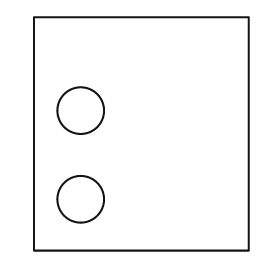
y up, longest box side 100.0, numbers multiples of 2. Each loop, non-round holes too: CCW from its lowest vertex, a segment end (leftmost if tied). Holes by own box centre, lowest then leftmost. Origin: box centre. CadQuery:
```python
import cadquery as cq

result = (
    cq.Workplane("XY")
    .moveTo(-46.0, -50.0)
    .lineTo(46.0, -50.0)
    .lineTo(46.0, 50.0)
    .lineTo(-46.0, 50.0)
    .close()
    .moveTo(-26.0, -28.0)
    .circle(10.0)
    .moveTo(-26.0, 10.0)
    .circle(10.0)
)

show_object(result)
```